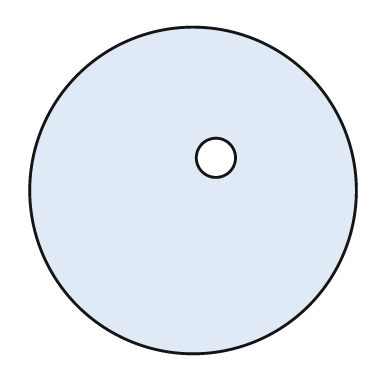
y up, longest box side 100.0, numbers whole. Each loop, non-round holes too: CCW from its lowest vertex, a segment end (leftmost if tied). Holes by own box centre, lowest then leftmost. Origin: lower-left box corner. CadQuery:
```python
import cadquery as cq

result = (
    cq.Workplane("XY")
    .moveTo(50.0, 50.0)
    .circle(50.0)
    .moveTo(57.0, 60.0)
    .circle(6.0)
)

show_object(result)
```